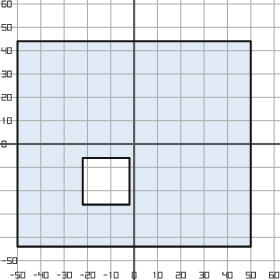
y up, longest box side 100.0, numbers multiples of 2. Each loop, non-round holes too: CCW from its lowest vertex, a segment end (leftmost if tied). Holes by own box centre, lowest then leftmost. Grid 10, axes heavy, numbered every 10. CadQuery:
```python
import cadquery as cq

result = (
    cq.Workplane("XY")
    .moveTo(-50.0, -44.0)
    .lineTo(50.0, -44.0)
    .lineTo(50.0, 44.0)
    .lineTo(-50.0, 44.0)
    .close()
    .moveTo(-22.0, -26.0)
    .lineTo(-2.0, -26.0)
    .lineTo(-2.0, -6.0)
    .lineTo(-22.0, -6.0)
    .close()
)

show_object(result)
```